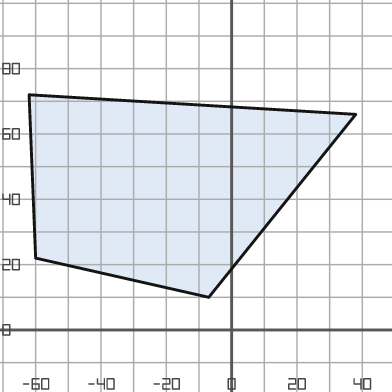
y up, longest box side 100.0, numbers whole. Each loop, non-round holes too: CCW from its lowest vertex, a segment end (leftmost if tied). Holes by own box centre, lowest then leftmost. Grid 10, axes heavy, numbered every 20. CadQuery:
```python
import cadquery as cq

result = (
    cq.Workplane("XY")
    .moveTo(-7.0, 10.0)
    .lineTo(38.0, 66.0)
    .lineTo(-62.0, 72.0)
    .lineTo(-60.0, 22.0)
    .close()
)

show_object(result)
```